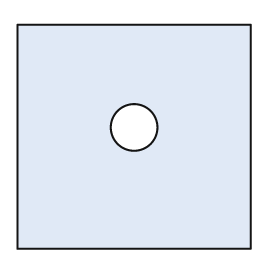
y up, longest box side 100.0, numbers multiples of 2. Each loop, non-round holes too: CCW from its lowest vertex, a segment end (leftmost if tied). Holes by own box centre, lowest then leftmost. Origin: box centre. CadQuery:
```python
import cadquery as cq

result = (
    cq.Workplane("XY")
    .moveTo(-50.0, -48.0)
    .lineTo(50.0, -48.0)
    .lineTo(50.0, 48.0)
    .lineTo(-50.0, 48.0)
    .close()
    .moveTo(0.0, 4.0)
    .circle(10.0)
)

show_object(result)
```